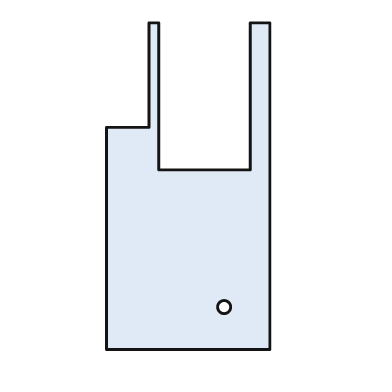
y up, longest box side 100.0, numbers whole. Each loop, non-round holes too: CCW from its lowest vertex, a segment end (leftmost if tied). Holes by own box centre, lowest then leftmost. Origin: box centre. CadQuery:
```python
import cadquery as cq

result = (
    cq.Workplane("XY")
    .moveTo(-25.0, -50.0)
    .lineTo(25.0, -50.0)
    .lineTo(25.0, 50.0)
    .lineTo(19.0, 50.0)
    .lineTo(19.0, 5.0)
    .lineTo(-9.0, 5.0)
    .lineTo(-9.0, 50.0)
    .lineTo(-12.0, 50.0)
    .lineTo(-12.0, 18.0)
    .lineTo(-25.0, 18.0)
    .close()
    .moveTo(11.0, -37.0)
    .circle(2.0)
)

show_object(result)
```